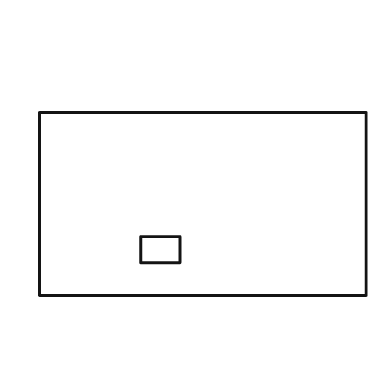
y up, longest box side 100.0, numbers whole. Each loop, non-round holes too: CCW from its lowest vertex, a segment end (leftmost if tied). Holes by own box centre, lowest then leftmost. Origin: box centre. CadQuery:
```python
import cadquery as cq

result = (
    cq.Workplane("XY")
    .moveTo(-50.0, -28.0)
    .lineTo(50.0, -28.0)
    .lineTo(50.0, 28.0)
    .lineTo(-50.0, 28.0)
    .close()
    .moveTo(-19.0, -18.0)
    .lineTo(-7.0, -18.0)
    .lineTo(-7.0, -10.0)
    .lineTo(-19.0, -10.0)
    .close()
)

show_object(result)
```